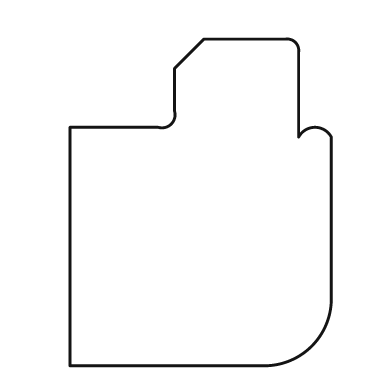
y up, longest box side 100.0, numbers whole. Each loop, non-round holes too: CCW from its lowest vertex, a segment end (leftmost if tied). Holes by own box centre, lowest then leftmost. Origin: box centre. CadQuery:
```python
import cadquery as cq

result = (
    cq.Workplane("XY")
    .moveTo(-40.0, -50.0)
    .lineTo(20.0, -50.0)
    .threePointArc((34.0, -44.0), (40.0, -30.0))
    .lineTo(40.0, 20.0)
    .threePointArc((35.0, 23.0), (30.0, 20.0))
    .lineTo(30.0, 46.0)
    .threePointArc((29.0, 49.0), (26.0, 50.0))
    .lineTo(1.0, 50.0)
    .lineTo(-8.0, 41.0)
    .lineTo(-8.0, 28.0)
    .threePointArc((-9.0, 24.0), (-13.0, 23.0))
    .lineTo(-40.0, 23.0)
    .close()
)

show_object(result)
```